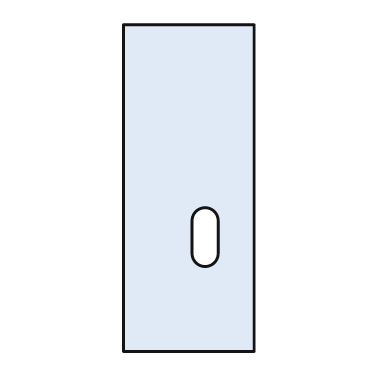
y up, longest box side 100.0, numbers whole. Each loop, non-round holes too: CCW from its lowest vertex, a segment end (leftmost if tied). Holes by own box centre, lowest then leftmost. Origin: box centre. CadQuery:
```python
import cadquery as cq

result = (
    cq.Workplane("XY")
    .moveTo(-20.0, -50.0)
    .lineTo(20.0, -50.0)
    .lineTo(20.0, 50.0)
    .lineTo(-20.0, 50.0)
    .close()
    .moveTo(1.0, -20.0)
    .threePointArc((5.0, -24.0), (9.0, -20.0))
    .lineTo(9.0, -10.0)
    .threePointArc((5.0, -6.0), (1.0, -10.0))
    .close()
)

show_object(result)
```